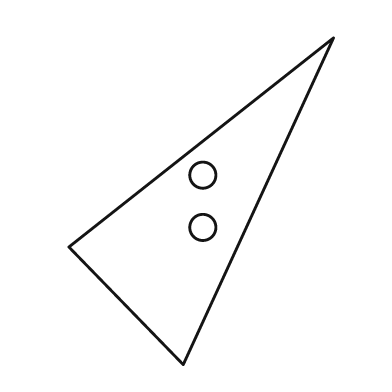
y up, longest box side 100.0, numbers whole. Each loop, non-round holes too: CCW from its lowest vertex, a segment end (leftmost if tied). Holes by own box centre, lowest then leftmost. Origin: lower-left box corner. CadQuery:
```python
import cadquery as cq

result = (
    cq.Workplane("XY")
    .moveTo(35.0, 0.0)
    .lineTo(81.0, 100.0)
    .lineTo(0.0, 36.0)
    .close()
    .moveTo(41.0, 42.0)
    .circle(4.0)
    .moveTo(41.0, 58.0)
    .circle(4.0)
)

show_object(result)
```